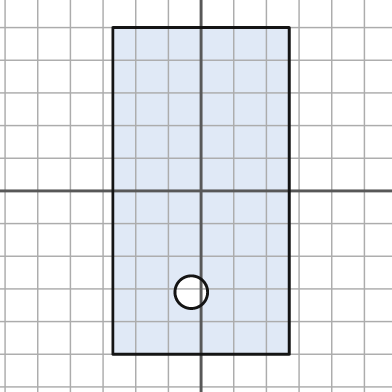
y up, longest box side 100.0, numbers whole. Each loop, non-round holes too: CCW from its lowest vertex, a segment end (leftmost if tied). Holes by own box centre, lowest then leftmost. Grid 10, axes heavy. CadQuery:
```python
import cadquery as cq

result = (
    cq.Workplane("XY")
    .moveTo(-27.0, -50.0)
    .lineTo(27.0, -50.0)
    .lineTo(27.0, 50.0)
    .lineTo(-27.0, 50.0)
    .close()
    .moveTo(-3.0, -31.0)
    .circle(5.0)
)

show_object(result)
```